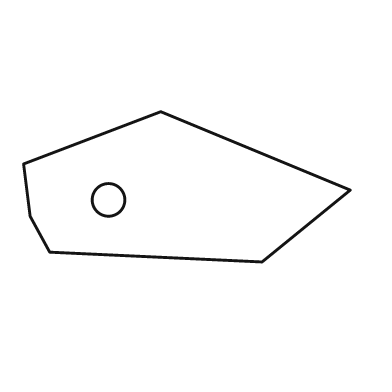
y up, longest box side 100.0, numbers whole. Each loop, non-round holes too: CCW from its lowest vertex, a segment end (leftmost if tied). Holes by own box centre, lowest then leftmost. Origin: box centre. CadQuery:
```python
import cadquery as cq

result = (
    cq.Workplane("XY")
    .moveTo(23.0, -23.0)
    .lineTo(50.0, -1.0)
    .lineTo(-8.0, 23.0)
    .lineTo(-50.0, 7.0)
    .lineTo(-48.0, -9.0)
    .lineTo(-42.0, -20.0)
    .close()
    .moveTo(-24.0, -4.0)
    .circle(5.0)
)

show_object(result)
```